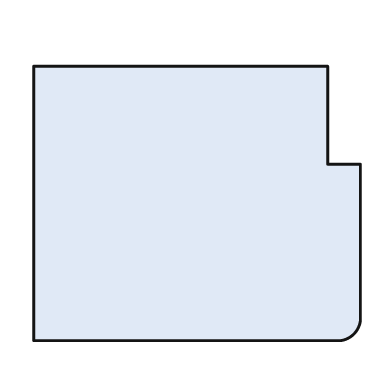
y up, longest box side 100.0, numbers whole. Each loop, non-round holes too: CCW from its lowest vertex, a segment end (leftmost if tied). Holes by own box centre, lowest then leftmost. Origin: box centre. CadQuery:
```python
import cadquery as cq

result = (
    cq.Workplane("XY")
    .moveTo(-50.0, -42.0)
    .lineTo(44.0, -42.0)
    .threePointArc((48.0, -40.0), (50.0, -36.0))
    .lineTo(50.0, 12.0)
    .lineTo(40.0, 12.0)
    .lineTo(40.0, 42.0)
    .lineTo(-50.0, 42.0)
    .close()
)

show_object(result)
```